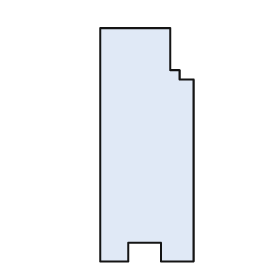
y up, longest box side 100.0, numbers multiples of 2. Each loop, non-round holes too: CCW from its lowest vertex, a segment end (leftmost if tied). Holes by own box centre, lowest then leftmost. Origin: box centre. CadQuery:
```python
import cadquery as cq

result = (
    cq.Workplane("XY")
    .moveTo(-20.0, -50.0)
    .lineTo(-8.0, -50.0)
    .lineTo(-8.0, -42.0)
    .lineTo(6.0, -42.0)
    .lineTo(6.0, -50.0)
    .lineTo(20.0, -50.0)
    .lineTo(20.0, 28.0)
    .lineTo(14.0, 28.0)
    .lineTo(14.0, 32.0)
    .lineTo(10.0, 32.0)
    .lineTo(10.0, 50.0)
    .lineTo(-20.0, 50.0)
    .close()
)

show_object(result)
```